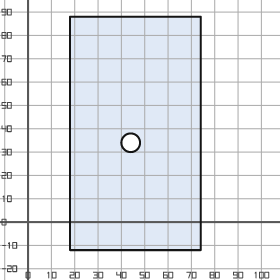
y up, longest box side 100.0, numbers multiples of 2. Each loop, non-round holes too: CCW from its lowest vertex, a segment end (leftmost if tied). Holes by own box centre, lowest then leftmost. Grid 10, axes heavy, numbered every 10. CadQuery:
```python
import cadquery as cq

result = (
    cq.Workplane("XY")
    .moveTo(18.0, -12.0)
    .lineTo(74.0, -12.0)
    .lineTo(74.0, 88.0)
    .lineTo(18.0, 88.0)
    .close()
    .moveTo(44.0, 34.0)
    .circle(4.0)
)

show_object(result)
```